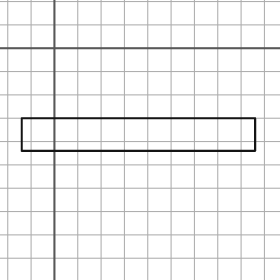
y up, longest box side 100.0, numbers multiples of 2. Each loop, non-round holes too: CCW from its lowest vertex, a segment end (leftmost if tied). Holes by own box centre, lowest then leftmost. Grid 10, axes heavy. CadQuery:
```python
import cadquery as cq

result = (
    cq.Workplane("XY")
    .moveTo(-14.0, -44.0)
    .lineTo(86.0, -44.0)
    .lineTo(86.0, -30.0)
    .lineTo(-14.0, -30.0)
    .close()
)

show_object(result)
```